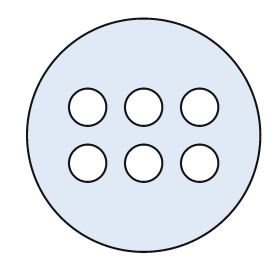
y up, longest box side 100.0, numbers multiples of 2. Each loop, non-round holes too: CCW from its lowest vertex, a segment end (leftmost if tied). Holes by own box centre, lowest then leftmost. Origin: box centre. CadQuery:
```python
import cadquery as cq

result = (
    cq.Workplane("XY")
    .moveTo(0.0, 0.0)
    .circle(50.0)
    .moveTo(-24.0, -12.0)
    .circle(8.0)
    .moveTo(0.0, -12.0)
    .circle(8.0)
    .moveTo(24.0, -12.0)
    .circle(8.0)
    .moveTo(-24.0, 12.0)
    .circle(8.0)
    .moveTo(0.0, 12.0)
    .circle(8.0)
    .moveTo(24.0, 12.0)
    .circle(8.0)
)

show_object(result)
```